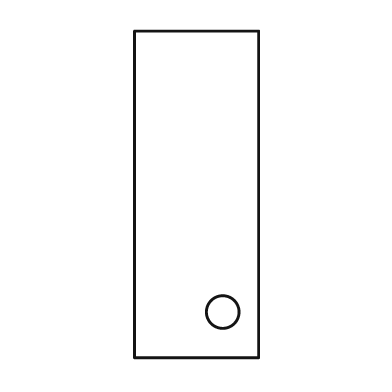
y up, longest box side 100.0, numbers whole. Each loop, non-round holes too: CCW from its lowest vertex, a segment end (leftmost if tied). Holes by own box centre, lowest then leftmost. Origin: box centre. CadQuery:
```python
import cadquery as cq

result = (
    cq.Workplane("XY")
    .moveTo(-19.0, -50.0)
    .lineTo(19.0, -50.0)
    .lineTo(19.0, 50.0)
    .lineTo(-19.0, 50.0)
    .close()
    .moveTo(8.0, -36.0)
    .circle(5.0)
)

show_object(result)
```